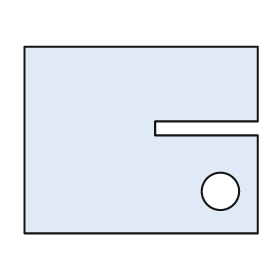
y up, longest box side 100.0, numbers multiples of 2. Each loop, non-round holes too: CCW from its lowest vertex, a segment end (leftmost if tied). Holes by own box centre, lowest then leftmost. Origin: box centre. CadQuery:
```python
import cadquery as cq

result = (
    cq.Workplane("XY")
    .moveTo(-50.0, -40.0)
    .lineTo(50.0, -40.0)
    .lineTo(50.0, 2.0)
    .lineTo(6.0, 2.0)
    .lineTo(6.0, 8.0)
    .lineTo(50.0, 8.0)
    .lineTo(50.0, 40.0)
    .lineTo(-50.0, 40.0)
    .close()
    .moveTo(34.0, -22.0)
    .circle(8.0)
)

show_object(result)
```